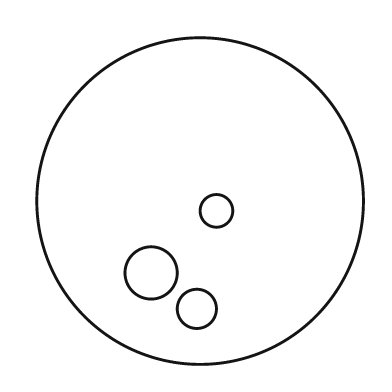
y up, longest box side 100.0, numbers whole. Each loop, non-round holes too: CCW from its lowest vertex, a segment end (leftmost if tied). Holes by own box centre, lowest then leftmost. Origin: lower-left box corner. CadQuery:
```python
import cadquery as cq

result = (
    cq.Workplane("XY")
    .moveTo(50.0, 50.0)
    .circle(50.0)
    .moveTo(49.0, 17.0)
    .circle(6.0)
    .moveTo(35.0, 28.0)
    .circle(8.0)
    .moveTo(55.0, 47.0)
    .circle(5.0)
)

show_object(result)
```